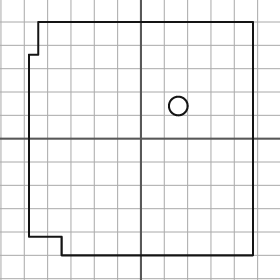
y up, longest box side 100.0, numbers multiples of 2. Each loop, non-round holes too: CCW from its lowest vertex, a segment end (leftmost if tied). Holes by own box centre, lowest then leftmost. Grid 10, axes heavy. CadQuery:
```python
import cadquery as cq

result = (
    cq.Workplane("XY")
    .moveTo(-34.0, -50.0)
    .lineTo(48.0, -50.0)
    .lineTo(48.0, 50.0)
    .lineTo(-44.0, 50.0)
    .lineTo(-44.0, 36.0)
    .lineTo(-48.0, 36.0)
    .lineTo(-48.0, -42.0)
    .lineTo(-34.0, -42.0)
    .close()
    .moveTo(16.0, 14.0)
    .circle(4.0)
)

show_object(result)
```